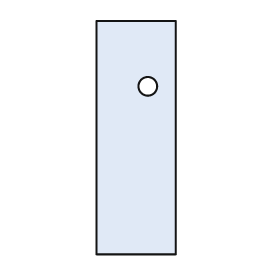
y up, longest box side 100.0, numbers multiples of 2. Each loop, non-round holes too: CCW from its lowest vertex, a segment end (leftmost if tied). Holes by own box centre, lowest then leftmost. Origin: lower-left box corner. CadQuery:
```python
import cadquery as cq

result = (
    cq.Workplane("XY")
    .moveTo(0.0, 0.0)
    .lineTo(34.0, 0.0)
    .lineTo(34.0, 100.0)
    .lineTo(0.0, 100.0)
    .close()
    .moveTo(22.0, 72.0)
    .circle(4.0)
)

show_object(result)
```